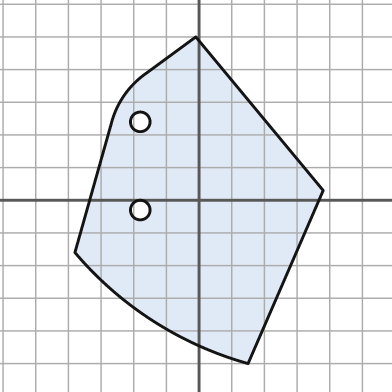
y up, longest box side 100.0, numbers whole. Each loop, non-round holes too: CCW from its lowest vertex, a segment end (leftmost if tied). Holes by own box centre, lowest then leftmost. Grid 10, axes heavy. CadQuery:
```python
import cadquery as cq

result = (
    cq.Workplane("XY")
    .moveTo(15.0, -50.0)
    .lineTo(38.0, 3.0)
    .lineTo(-1.0, 50.0)
    .lineTo(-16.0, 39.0)
    .threePointArc((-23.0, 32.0), (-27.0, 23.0))
    .lineTo(-38.0, -16.0)
    .threePointArc((-14.0, -37.0), (15.0, -50.0))
    .close()
    .moveTo(-18.0, -3.0)
    .circle(3.0)
    .moveTo(-18.0, 24.0)
    .circle(3.0)
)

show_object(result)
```